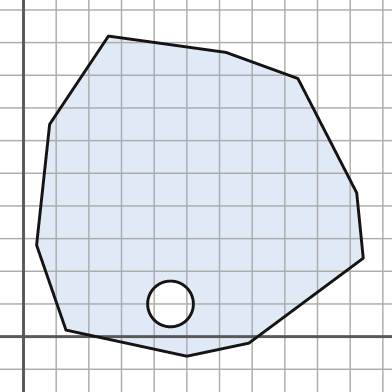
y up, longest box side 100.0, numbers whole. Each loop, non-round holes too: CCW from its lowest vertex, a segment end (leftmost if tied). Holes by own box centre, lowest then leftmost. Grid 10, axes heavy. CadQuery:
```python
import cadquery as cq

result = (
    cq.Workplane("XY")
    .moveTo(50.0, -6.0)
    .lineTo(69.0, -2.0)
    .lineTo(104.0, 24.0)
    .lineTo(102.0, 44.0)
    .lineTo(84.0, 79.0)
    .lineTo(62.0, 87.0)
    .lineTo(26.0, 92.0)
    .lineTo(8.0, 65.0)
    .lineTo(4.0, 28.0)
    .lineTo(13.0, 2.0)
    .close()
    .moveTo(45.0, 10.0)
    .circle(7.0)
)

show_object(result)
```